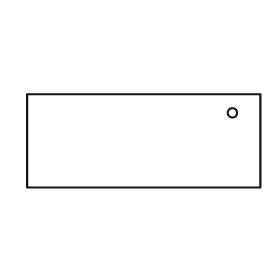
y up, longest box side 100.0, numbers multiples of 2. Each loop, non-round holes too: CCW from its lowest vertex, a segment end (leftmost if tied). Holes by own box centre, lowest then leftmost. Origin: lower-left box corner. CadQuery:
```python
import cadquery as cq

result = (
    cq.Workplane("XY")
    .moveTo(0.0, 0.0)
    .lineTo(100.0, 0.0)
    .lineTo(100.0, 40.0)
    .lineTo(0.0, 40.0)
    .close()
    .moveTo(88.0, 32.0)
    .circle(2.0)
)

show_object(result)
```